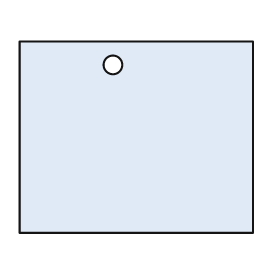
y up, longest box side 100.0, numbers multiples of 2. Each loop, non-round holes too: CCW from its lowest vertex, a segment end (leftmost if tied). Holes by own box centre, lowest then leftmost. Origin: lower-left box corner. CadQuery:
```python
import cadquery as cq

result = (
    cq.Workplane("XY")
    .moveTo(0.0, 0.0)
    .lineTo(100.0, 0.0)
    .lineTo(100.0, 82.0)
    .lineTo(0.0, 82.0)
    .close()
    .moveTo(40.0, 72.0)
    .circle(4.0)
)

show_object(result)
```